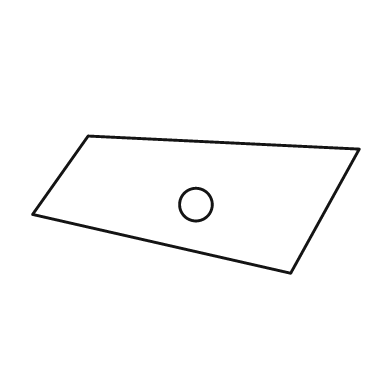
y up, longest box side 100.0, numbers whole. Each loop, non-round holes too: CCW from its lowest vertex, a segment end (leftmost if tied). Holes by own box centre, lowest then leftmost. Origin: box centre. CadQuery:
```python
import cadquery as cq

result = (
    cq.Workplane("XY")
    .moveTo(29.0, -21.0)
    .lineTo(50.0, 17.0)
    .lineTo(-33.0, 21.0)
    .lineTo(-50.0, -3.0)
    .close()
    .moveTo(0.0, 0.0)
    .circle(5.0)
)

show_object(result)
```